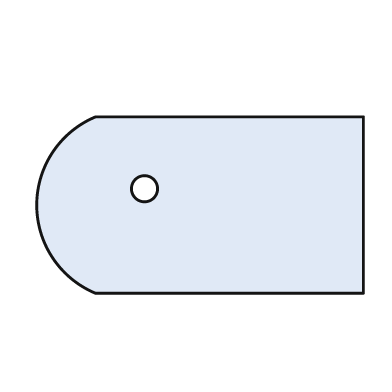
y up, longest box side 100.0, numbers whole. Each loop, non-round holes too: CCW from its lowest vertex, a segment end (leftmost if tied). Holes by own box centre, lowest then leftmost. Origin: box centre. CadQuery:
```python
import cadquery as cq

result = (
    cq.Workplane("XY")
    .moveTo(-32.0, -27.0)
    .lineTo(50.0, -27.0)
    .lineTo(50.0, 27.0)
    .lineTo(-32.0, 27.0)
    .threePointArc((-50.0, 0.0), (-32.0, -27.0))
    .close()
    .moveTo(-17.0, 5.0)
    .circle(4.0)
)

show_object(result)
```